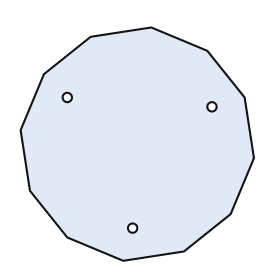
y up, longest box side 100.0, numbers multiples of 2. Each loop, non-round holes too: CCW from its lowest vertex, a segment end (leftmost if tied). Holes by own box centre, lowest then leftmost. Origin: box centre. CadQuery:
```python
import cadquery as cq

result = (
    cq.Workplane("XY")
    .moveTo(-6.0, -50.0)
    .lineTo(20.0, -46.0)
    .lineTo(40.0, -30.0)
    .lineTo(50.0, -6.0)
    .lineTo(46.0, 20.0)
    .lineTo(30.0, 40.0)
    .lineTo(6.0, 50.0)
    .lineTo(-20.0, 46.0)
    .lineTo(-40.0, 30.0)
    .lineTo(-50.0, 6.0)
    .lineTo(-46.0, -20.0)
    .lineTo(-30.0, -40.0)
    .close()
    .moveTo(-2.0, -36.0)
    .circle(2.0)
    .moveTo(32.0, 16.0)
    .circle(2.0)
    .moveTo(-30.0, 20.0)
    .circle(2.0)
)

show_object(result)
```